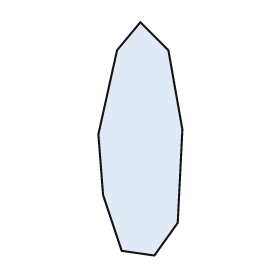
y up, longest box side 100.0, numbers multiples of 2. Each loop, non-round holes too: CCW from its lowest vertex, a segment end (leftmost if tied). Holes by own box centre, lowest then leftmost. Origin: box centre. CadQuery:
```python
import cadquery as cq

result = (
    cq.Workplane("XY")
    .moveTo(6.0, -50.0)
    .lineTo(16.0, -36.0)
    .lineTo(18.0, 4.0)
    .lineTo(12.0, 38.0)
    .lineTo(0.0, 50.0)
    .lineTo(-10.0, 38.0)
    .lineTo(-18.0, 2.0)
    .lineTo(-16.0, -24.0)
    .lineTo(-8.0, -48.0)
    .close()
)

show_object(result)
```